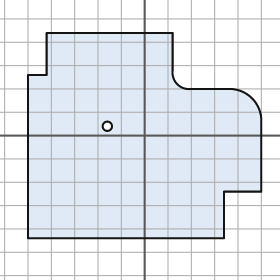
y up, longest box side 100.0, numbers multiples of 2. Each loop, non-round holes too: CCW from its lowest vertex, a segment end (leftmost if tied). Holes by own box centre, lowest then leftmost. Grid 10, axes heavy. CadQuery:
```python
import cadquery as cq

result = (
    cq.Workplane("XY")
    .moveTo(-50.0, -44.0)
    .lineTo(34.0, -44.0)
    .lineTo(34.0, -24.0)
    .lineTo(50.0, -24.0)
    .lineTo(50.0, 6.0)
    .threePointArc((46.0, 16.0), (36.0, 20.0))
    .lineTo(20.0, 20.0)
    .threePointArc((14.0, 22.0), (12.0, 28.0))
    .lineTo(12.0, 44.0)
    .lineTo(-42.0, 44.0)
    .lineTo(-42.0, 26.0)
    .lineTo(-50.0, 26.0)
    .close()
    .moveTo(-16.0, 4.0)
    .circle(2.0)
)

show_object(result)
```